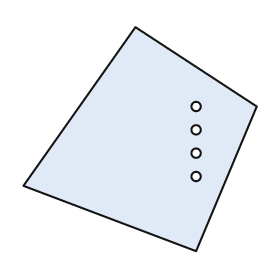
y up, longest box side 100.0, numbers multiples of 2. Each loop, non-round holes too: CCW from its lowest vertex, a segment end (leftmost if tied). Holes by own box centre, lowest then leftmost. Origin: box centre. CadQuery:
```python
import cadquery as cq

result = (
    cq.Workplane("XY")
    .moveTo(24.0, -48.0)
    .lineTo(50.0, 14.0)
    .lineTo(-2.0, 48.0)
    .lineTo(-50.0, -20.0)
    .close()
    .moveTo(24.0, -16.0)
    .circle(2.0)
    .moveTo(24.0, -6.0)
    .circle(2.0)
    .moveTo(24.0, 4.0)
    .circle(2.0)
    .moveTo(24.0, 14.0)
    .circle(2.0)
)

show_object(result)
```